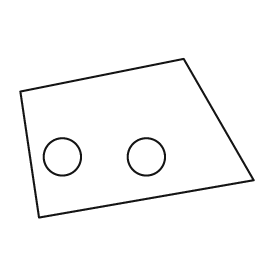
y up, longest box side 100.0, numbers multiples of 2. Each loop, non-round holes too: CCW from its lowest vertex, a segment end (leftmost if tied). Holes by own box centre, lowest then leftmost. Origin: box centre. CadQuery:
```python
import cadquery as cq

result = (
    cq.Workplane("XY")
    .moveTo(-42.0, -34.0)
    .lineTo(50.0, -18.0)
    .lineTo(20.0, 34.0)
    .lineTo(-50.0, 20.0)
    .close()
    .moveTo(-32.0, -8.0)
    .circle(8.0)
    .moveTo(4.0, -8.0)
    .circle(8.0)
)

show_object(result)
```